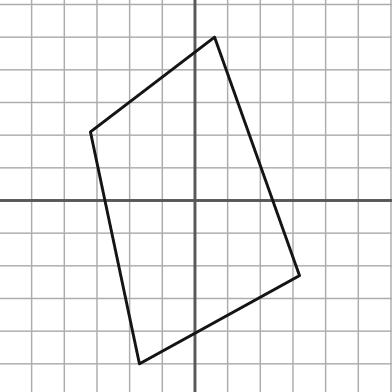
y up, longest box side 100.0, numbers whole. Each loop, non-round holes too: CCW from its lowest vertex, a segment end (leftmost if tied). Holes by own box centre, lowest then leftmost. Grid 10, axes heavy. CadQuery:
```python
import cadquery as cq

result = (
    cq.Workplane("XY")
    .moveTo(-17.0, -50.0)
    .lineTo(32.0, -23.0)
    .lineTo(6.0, 50.0)
    .lineTo(-32.0, 21.0)
    .close()
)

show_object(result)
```